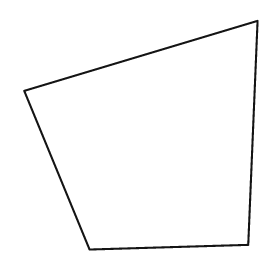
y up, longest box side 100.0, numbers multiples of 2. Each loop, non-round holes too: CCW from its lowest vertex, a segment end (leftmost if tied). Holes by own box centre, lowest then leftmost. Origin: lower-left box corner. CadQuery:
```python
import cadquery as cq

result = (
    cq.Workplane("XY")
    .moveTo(28.0, 0.0)
    .lineTo(96.0, 2.0)
    .lineTo(100.0, 98.0)
    .lineTo(0.0, 68.0)
    .close()
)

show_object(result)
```